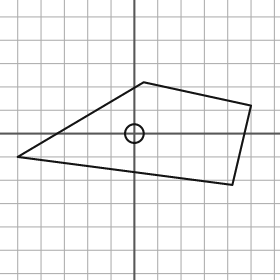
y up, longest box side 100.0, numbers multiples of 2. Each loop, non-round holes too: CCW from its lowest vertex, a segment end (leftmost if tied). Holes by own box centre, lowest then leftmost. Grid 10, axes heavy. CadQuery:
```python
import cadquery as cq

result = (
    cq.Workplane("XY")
    .moveTo(42.0, -22.0)
    .lineTo(50.0, 12.0)
    .lineTo(4.0, 22.0)
    .lineTo(-50.0, -10.0)
    .close()
    .moveTo(0.0, 0.0)
    .circle(4.0)
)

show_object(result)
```